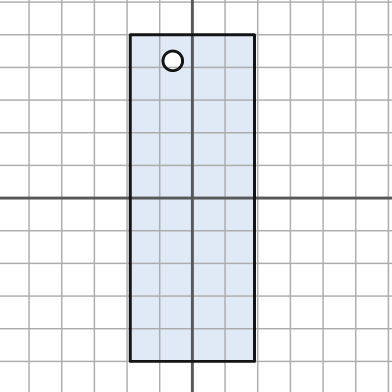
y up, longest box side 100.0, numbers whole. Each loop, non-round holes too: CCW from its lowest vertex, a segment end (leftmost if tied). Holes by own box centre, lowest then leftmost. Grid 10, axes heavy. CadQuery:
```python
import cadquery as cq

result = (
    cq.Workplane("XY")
    .moveTo(-19.0, -50.0)
    .lineTo(19.0, -50.0)
    .lineTo(19.0, 50.0)
    .lineTo(-19.0, 50.0)
    .close()
    .moveTo(-6.0, 42.0)
    .circle(3.0)
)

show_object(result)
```